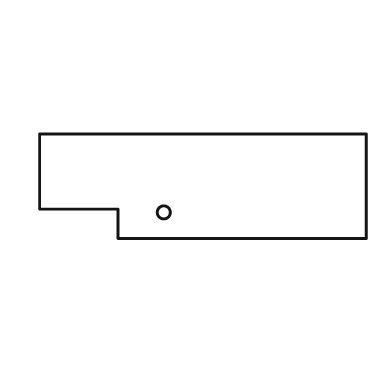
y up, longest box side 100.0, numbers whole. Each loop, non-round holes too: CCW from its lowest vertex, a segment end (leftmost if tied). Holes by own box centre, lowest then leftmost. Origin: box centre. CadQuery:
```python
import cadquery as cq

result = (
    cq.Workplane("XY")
    .moveTo(-26.0, -16.0)
    .lineTo(50.0, -16.0)
    .lineTo(50.0, 16.0)
    .lineTo(-50.0, 16.0)
    .lineTo(-50.0, -7.0)
    .lineTo(-26.0, -7.0)
    .close()
    .moveTo(-12.0, -8.0)
    .circle(2.0)
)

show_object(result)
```